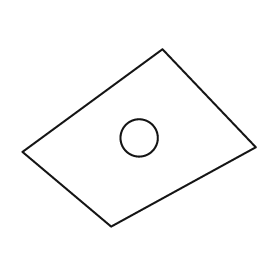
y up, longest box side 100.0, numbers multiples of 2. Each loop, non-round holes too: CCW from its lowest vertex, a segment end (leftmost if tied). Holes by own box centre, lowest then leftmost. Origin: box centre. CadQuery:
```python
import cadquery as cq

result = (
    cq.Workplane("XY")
    .moveTo(-12.0, -38.0)
    .lineTo(50.0, -4.0)
    .lineTo(10.0, 38.0)
    .lineTo(-50.0, -6.0)
    .close()
    .moveTo(0.0, 0.0)
    .circle(8.0)
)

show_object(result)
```